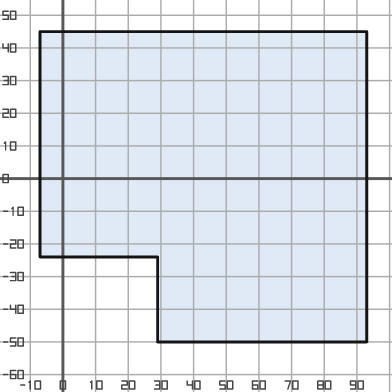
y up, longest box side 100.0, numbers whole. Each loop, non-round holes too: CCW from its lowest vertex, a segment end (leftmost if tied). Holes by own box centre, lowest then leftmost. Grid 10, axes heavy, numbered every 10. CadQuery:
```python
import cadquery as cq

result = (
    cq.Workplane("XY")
    .moveTo(29.0, -50.0)
    .lineTo(93.0, -50.0)
    .lineTo(93.0, 45.0)
    .lineTo(-7.0, 45.0)
    .lineTo(-7.0, -24.0)
    .lineTo(29.0, -24.0)
    .close()
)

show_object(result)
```